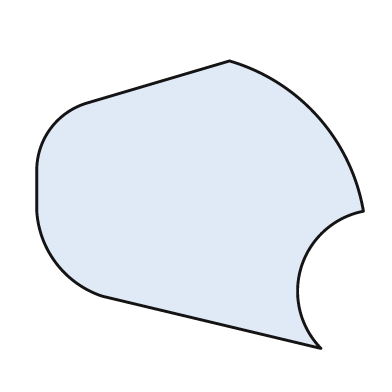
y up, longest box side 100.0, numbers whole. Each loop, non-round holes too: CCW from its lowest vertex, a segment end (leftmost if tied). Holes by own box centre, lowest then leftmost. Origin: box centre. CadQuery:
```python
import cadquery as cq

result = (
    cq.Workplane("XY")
    .moveTo(37.0, -44.0)
    .threePointArc((31.0, -19.0), (50.0, -2.0))
    .threePointArc((36.0, 27.0), (9.0, 44.0))
    .lineTo(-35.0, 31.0)
    .threePointArc((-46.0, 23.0), (-50.0, 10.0))
    .lineTo(-50.0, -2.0)
    .threePointArc((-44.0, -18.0), (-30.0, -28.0))
    .close()
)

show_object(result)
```